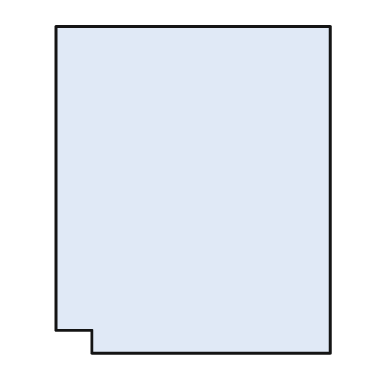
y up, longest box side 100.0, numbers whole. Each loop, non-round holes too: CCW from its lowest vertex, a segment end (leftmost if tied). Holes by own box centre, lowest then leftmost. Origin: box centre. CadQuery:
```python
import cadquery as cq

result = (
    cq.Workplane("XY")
    .moveTo(-31.0, -50.0)
    .lineTo(42.0, -50.0)
    .lineTo(42.0, 50.0)
    .lineTo(-42.0, 50.0)
    .lineTo(-42.0, -43.0)
    .lineTo(-31.0, -43.0)
    .close()
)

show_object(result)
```